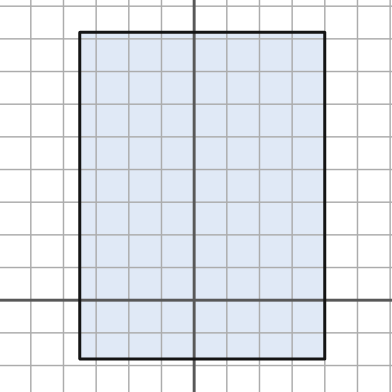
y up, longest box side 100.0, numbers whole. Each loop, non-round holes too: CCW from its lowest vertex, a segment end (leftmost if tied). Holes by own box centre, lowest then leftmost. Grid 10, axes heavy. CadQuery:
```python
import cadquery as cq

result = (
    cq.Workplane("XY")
    .moveTo(-35.0, -18.0)
    .lineTo(40.0, -18.0)
    .lineTo(40.0, 82.0)
    .lineTo(-35.0, 82.0)
    .close()
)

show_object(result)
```